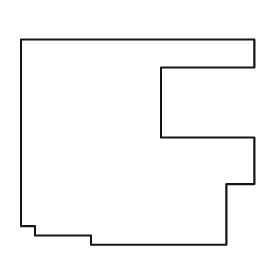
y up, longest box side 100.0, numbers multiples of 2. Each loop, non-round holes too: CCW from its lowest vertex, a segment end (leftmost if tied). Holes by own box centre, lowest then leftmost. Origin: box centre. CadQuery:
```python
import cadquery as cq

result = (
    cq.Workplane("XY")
    .moveTo(-20.0, -44.0)
    .lineTo(38.0, -44.0)
    .lineTo(38.0, -18.0)
    .lineTo(50.0, -18.0)
    .lineTo(50.0, 2.0)
    .lineTo(10.0, 2.0)
    .lineTo(10.0, 32.0)
    .lineTo(50.0, 32.0)
    .lineTo(50.0, 44.0)
    .lineTo(-50.0, 44.0)
    .lineTo(-50.0, -36.0)
    .lineTo(-44.0, -36.0)
    .lineTo(-44.0, -40.0)
    .lineTo(-20.0, -40.0)
    .close()
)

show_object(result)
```